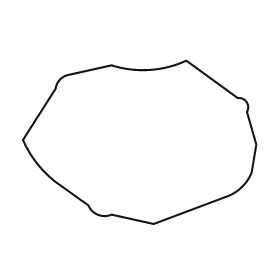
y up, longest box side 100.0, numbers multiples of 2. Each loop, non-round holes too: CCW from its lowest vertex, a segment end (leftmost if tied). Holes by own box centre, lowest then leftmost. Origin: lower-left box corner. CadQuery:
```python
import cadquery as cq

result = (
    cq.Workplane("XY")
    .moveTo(56.0, 0.0)
    .lineTo(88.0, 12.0)
    .threePointArc((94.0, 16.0), (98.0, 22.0))
    .lineTo(100.0, 34.0)
    .lineTo(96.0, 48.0)
    .threePointArc((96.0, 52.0), (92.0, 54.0))
    .lineTo(70.0, 70.0)
    .threePointArc((54.0, 66.0), (38.0, 68.0))
    .lineTo(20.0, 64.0)
    .threePointArc((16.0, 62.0), (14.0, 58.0))
    .lineTo(0.0, 36.0)
    .threePointArc((6.0, 26.0), (14.0, 18.0))
    .lineTo(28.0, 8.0)
    .threePointArc((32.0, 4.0), (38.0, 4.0))
    .close()
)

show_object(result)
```